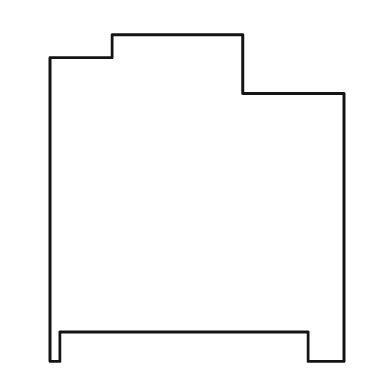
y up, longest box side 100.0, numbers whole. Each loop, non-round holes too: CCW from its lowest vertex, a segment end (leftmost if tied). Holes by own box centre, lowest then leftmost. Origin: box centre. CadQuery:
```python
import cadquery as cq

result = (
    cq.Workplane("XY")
    .moveTo(-45.0, -50.0)
    .lineTo(-42.0, -50.0)
    .lineTo(-42.0, -41.0)
    .lineTo(34.0, -41.0)
    .lineTo(34.0, -50.0)
    .lineTo(45.0, -50.0)
    .lineTo(45.0, 32.0)
    .lineTo(14.0, 32.0)
    .lineTo(14.0, 50.0)
    .lineTo(-26.0, 50.0)
    .lineTo(-26.0, 43.0)
    .lineTo(-45.0, 43.0)
    .close()
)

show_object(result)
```